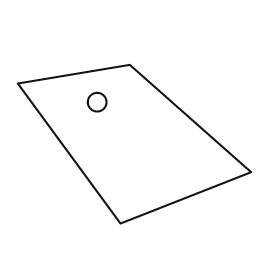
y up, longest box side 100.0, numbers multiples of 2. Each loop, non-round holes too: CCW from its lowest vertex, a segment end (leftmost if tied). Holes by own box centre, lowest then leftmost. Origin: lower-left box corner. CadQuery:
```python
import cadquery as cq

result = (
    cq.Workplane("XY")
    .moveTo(44.0, 0.0)
    .lineTo(100.0, 22.0)
    .lineTo(48.0, 68.0)
    .lineTo(0.0, 60.0)
    .close()
    .moveTo(34.0, 52.0)
    .circle(4.0)
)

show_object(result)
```